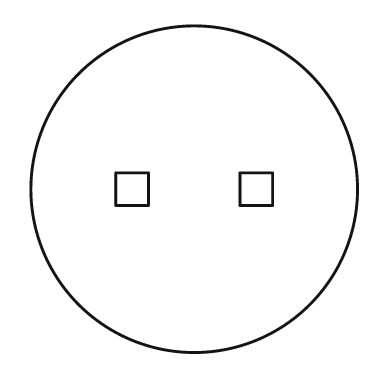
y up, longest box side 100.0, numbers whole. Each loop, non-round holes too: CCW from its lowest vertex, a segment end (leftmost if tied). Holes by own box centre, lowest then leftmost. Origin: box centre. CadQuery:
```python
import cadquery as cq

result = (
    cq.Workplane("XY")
    .moveTo(0.0, 0.0)
    .circle(50.0)
    .moveTo(-24.0, -5.0)
    .lineTo(-14.0, -5.0)
    .lineTo(-14.0, 5.0)
    .lineTo(-24.0, 5.0)
    .close()
    .moveTo(14.0, -5.0)
    .lineTo(24.0, -5.0)
    .lineTo(24.0, 5.0)
    .lineTo(14.0, 5.0)
    .close()
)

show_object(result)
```